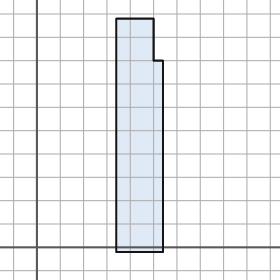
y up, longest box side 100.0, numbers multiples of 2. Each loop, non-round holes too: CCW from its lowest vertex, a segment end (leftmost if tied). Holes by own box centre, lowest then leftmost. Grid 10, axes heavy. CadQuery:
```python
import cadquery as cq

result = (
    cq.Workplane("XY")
    .moveTo(34.0, -2.0)
    .lineTo(54.0, -2.0)
    .lineTo(54.0, 80.0)
    .lineTo(50.0, 80.0)
    .lineTo(50.0, 98.0)
    .lineTo(34.0, 98.0)
    .close()
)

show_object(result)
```